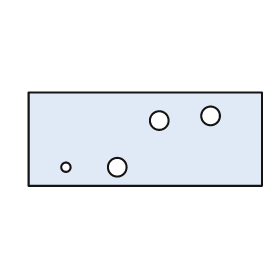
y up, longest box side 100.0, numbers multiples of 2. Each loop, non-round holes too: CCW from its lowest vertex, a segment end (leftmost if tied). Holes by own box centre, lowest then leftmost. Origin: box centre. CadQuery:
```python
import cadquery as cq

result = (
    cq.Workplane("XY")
    .moveTo(-50.0, -20.0)
    .lineTo(50.0, -20.0)
    .lineTo(50.0, 20.0)
    .lineTo(-50.0, 20.0)
    .close()
    .moveTo(-34.0, -12.0)
    .circle(2.0)
    .moveTo(-12.0, -12.0)
    .circle(4.0)
    .moveTo(6.0, 8.0)
    .circle(4.0)
    .moveTo(28.0, 10.0)
    .circle(4.0)
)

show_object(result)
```